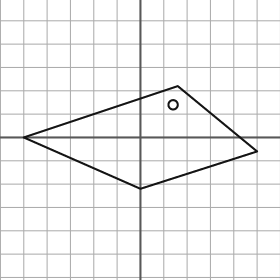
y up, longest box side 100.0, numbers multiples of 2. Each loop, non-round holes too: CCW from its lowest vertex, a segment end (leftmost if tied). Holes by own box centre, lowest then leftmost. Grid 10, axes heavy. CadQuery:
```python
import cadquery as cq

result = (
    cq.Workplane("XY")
    .moveTo(0.0, -22.0)
    .lineTo(50.0, -6.0)
    .lineTo(16.0, 22.0)
    .lineTo(-50.0, 0.0)
    .close()
    .moveTo(14.0, 14.0)
    .circle(2.0)
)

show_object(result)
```